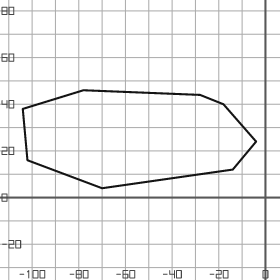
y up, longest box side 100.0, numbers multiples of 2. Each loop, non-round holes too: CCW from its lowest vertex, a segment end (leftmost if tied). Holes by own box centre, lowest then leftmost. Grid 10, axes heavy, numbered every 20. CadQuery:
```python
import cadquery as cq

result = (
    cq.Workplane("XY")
    .moveTo(-70.0, 4.0)
    .lineTo(-14.0, 12.0)
    .lineTo(-4.0, 24.0)
    .lineTo(-18.0, 40.0)
    .lineTo(-28.0, 44.0)
    .lineTo(-78.0, 46.0)
    .lineTo(-104.0, 38.0)
    .lineTo(-102.0, 16.0)
    .close()
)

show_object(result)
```